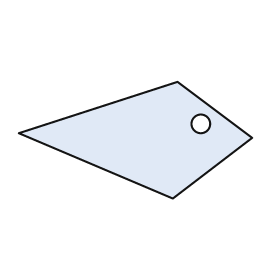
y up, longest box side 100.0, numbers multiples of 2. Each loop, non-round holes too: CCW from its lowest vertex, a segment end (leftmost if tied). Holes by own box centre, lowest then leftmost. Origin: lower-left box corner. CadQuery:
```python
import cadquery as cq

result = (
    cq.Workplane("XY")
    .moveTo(66.0, 0.0)
    .lineTo(100.0, 26.0)
    .lineTo(68.0, 50.0)
    .lineTo(0.0, 28.0)
    .close()
    .moveTo(78.0, 32.0)
    .circle(4.0)
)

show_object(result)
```